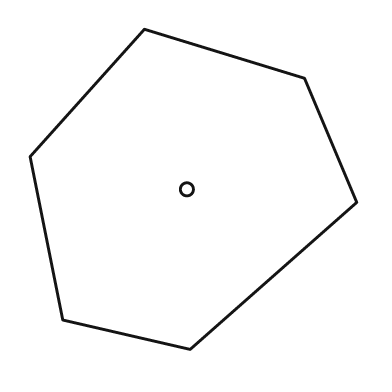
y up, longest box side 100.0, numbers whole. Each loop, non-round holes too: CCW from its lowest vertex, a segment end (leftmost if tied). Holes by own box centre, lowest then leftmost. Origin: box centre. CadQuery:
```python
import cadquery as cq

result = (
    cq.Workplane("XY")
    .moveTo(-1.0, -49.0)
    .lineTo(50.0, -4.0)
    .lineTo(34.0, 34.0)
    .lineTo(-15.0, 49.0)
    .lineTo(-50.0, 10.0)
    .lineTo(-40.0, -40.0)
    .close()
    .moveTo(-2.0, 0.0)
    .circle(2.0)
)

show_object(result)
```